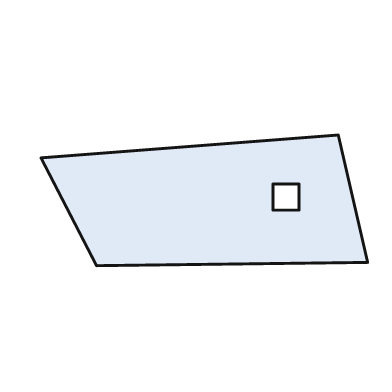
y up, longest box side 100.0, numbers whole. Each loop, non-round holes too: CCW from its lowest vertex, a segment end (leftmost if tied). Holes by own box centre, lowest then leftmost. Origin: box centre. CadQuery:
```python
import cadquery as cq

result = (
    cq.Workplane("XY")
    .moveTo(-33.0, -20.0)
    .lineTo(50.0, -19.0)
    .lineTo(41.0, 20.0)
    .lineTo(-50.0, 13.0)
    .close()
    .moveTo(21.0, -3.0)
    .lineTo(29.0, -3.0)
    .lineTo(29.0, 5.0)
    .lineTo(21.0, 5.0)
    .close()
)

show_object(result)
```